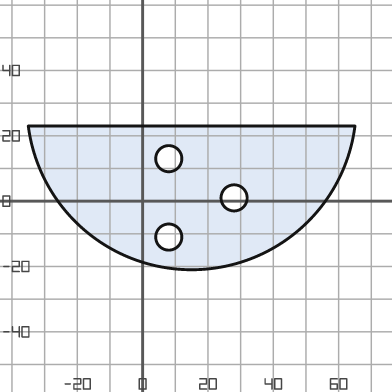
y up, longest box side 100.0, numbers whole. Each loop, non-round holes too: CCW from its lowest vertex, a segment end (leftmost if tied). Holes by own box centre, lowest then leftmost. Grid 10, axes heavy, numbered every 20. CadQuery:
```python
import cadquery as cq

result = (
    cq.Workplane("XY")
    .moveTo(-35.0, 23.0)
    .threePointArc((15.0, -21.0), (65.0, 23.0))
    .close()
    .moveTo(8.0, -11.0)
    .circle(4.0)
    .moveTo(28.0, 1.0)
    .circle(4.0)
    .moveTo(8.0, 13.0)
    .circle(4.0)
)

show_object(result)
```